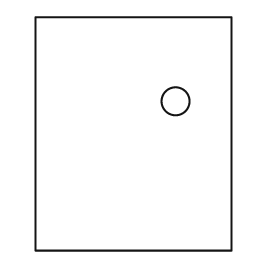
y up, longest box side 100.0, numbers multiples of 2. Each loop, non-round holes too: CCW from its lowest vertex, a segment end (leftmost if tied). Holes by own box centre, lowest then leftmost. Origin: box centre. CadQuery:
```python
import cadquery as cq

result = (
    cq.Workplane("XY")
    .moveTo(-42.0, -50.0)
    .lineTo(42.0, -50.0)
    .lineTo(42.0, 50.0)
    .lineTo(-42.0, 50.0)
    .close()
    .moveTo(18.0, 14.0)
    .circle(6.0)
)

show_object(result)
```